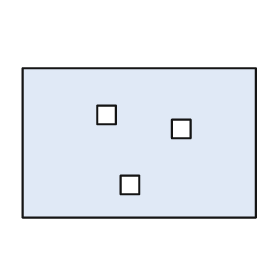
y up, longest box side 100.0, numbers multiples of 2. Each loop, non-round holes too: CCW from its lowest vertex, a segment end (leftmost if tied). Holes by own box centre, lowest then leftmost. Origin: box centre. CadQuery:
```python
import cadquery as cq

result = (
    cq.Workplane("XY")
    .moveTo(-50.0, -32.0)
    .lineTo(50.0, -32.0)
    .lineTo(50.0, 32.0)
    .lineTo(-50.0, 32.0)
    .close()
    .moveTo(-8.0, -22.0)
    .lineTo(0.0, -22.0)
    .lineTo(0.0, -14.0)
    .lineTo(-8.0, -14.0)
    .close()
    .moveTo(14.0, 2.0)
    .lineTo(22.0, 2.0)
    .lineTo(22.0, 10.0)
    .lineTo(14.0, 10.0)
    .close()
    .moveTo(-18.0, 8.0)
    .lineTo(-10.0, 8.0)
    .lineTo(-10.0, 16.0)
    .lineTo(-18.0, 16.0)
    .close()
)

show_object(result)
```